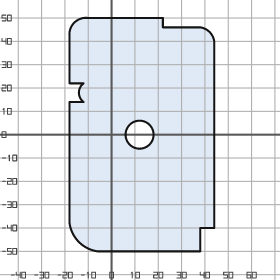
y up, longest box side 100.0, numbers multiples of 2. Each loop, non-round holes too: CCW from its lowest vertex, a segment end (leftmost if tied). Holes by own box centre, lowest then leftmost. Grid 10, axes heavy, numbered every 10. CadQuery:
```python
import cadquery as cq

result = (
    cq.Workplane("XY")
    .moveTo(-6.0, -50.0)
    .lineTo(38.0, -50.0)
    .lineTo(38.0, -40.0)
    .lineTo(44.0, -40.0)
    .lineTo(44.0, 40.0)
    .threePointArc((42.0, 44.0), (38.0, 46.0))
    .lineTo(22.0, 46.0)
    .lineTo(22.0, 50.0)
    .lineTo(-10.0, 50.0)
    .threePointArc((-16.0, 48.0), (-18.0, 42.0))
    .lineTo(-18.0, 22.0)
    .lineTo(-12.0, 22.0)
    .threePointArc((-14.0, 18.0), (-12.0, 14.0))
    .lineTo(-18.0, 14.0)
    .lineTo(-18.0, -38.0)
    .threePointArc((-14.0, -46.0), (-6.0, -50.0))
    .close()
    .moveTo(12.0, 0.0)
    .circle(6.0)
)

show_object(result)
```